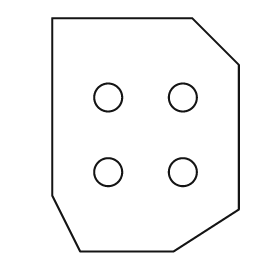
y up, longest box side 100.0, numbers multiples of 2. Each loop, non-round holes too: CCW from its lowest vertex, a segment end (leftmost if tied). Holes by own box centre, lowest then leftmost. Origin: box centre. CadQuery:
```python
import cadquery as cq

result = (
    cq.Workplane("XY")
    .moveTo(-28.0, -50.0)
    .lineTo(12.0, -50.0)
    .lineTo(40.0, -32.0)
    .lineTo(40.0, 30.0)
    .lineTo(20.0, 50.0)
    .lineTo(-40.0, 50.0)
    .lineTo(-40.0, -26.0)
    .close()
    .moveTo(-16.0, -16.0)
    .circle(6.0)
    .moveTo(16.0, -16.0)
    .circle(6.0)
    .moveTo(-16.0, 16.0)
    .circle(6.0)
    .moveTo(16.0, 16.0)
    .circle(6.0)
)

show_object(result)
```